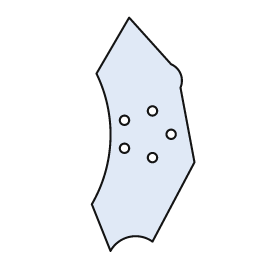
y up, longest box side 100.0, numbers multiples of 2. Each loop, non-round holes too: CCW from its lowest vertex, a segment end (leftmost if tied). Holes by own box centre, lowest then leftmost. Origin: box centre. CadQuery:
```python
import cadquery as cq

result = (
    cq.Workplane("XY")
    .moveTo(-14.0, -50.0)
    .threePointArc((-6.0, -44.0), (4.0, -46.0))
    .lineTo(22.0, -12.0)
    .lineTo(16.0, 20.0)
    .threePointArc((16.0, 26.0), (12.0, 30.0))
    .lineTo(-6.0, 50.0)
    .lineTo(-20.0, 26.0)
    .threePointArc((-14.0, -2.0), (-22.0, -30.0))
    .close()
    .moveTo(4.0, -10.0)
    .circle(2.0)
    .moveTo(-8.0, -6.0)
    .circle(2.0)
    .moveTo(12.0, 0.0)
    .circle(2.0)
    .moveTo(-8.0, 6.0)
    .circle(2.0)
    .moveTo(4.0, 10.0)
    .circle(2.0)
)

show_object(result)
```